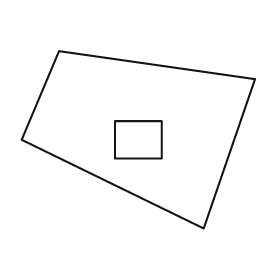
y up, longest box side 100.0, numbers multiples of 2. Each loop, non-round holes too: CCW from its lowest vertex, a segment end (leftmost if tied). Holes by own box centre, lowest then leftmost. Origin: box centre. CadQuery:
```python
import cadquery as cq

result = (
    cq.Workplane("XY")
    .moveTo(28.0, -38.0)
    .lineTo(50.0, 26.0)
    .lineTo(-34.0, 38.0)
    .lineTo(-50.0, 0.0)
    .close()
    .moveTo(-10.0, -8.0)
    .lineTo(10.0, -8.0)
    .lineTo(10.0, 8.0)
    .lineTo(-10.0, 8.0)
    .close()
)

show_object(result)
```